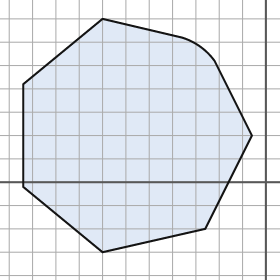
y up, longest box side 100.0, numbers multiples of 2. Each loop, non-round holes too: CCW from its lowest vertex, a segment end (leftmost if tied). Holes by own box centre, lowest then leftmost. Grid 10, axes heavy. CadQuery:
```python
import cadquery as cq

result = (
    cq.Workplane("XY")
    .moveTo(-70.0, -30.0)
    .lineTo(-26.0, -20.0)
    .lineTo(-6.0, 20.0)
    .lineTo(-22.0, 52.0)
    .threePointArc((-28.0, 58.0), (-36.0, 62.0))
    .lineTo(-70.0, 70.0)
    .lineTo(-104.0, 42.0)
    .lineTo(-104.0, -2.0)
    .close()
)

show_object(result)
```